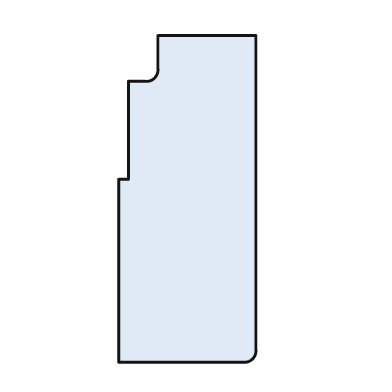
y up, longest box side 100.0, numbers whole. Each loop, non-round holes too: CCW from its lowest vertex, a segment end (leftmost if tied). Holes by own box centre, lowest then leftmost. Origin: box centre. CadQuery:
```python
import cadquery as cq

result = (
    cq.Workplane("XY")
    .moveTo(-21.0, -50.0)
    .lineTo(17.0, -50.0)
    .threePointArc((20.0, -49.0), (21.0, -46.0))
    .lineTo(21.0, 50.0)
    .lineTo(-9.0, 50.0)
    .lineTo(-9.0, 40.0)
    .threePointArc((-10.0, 37.0), (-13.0, 36.0))
    .lineTo(-18.0, 36.0)
    .lineTo(-18.0, 6.0)
    .lineTo(-21.0, 6.0)
    .close()
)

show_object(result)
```